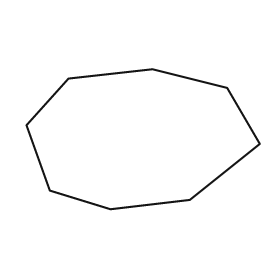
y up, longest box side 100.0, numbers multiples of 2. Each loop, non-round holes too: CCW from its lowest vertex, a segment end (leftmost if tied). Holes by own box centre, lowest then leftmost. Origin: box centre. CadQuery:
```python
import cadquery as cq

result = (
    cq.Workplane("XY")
    .moveTo(-14.0, -30.0)
    .lineTo(20.0, -26.0)
    .lineTo(50.0, -2.0)
    .lineTo(36.0, 22.0)
    .lineTo(4.0, 30.0)
    .lineTo(-32.0, 26.0)
    .lineTo(-50.0, 6.0)
    .lineTo(-40.0, -22.0)
    .close()
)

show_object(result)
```